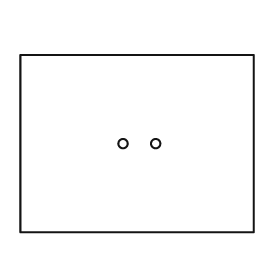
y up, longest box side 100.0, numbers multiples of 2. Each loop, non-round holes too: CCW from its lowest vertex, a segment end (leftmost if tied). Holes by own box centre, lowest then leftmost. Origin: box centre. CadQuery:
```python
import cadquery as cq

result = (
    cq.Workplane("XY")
    .moveTo(-50.0, -38.0)
    .lineTo(50.0, -38.0)
    .lineTo(50.0, 38.0)
    .lineTo(-50.0, 38.0)
    .close()
    .moveTo(-6.0, 0.0)
    .circle(2.0)
    .moveTo(8.0, 0.0)
    .circle(2.0)
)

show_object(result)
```